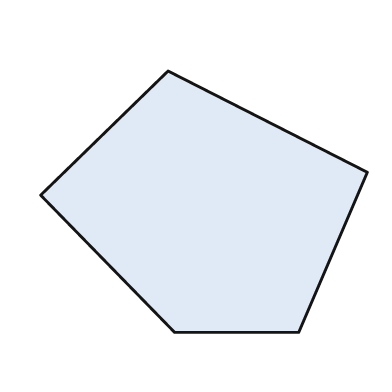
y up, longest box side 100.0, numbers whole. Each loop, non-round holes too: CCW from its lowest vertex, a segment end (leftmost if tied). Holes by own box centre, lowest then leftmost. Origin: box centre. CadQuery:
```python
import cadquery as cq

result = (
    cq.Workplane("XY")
    .moveTo(-9.0, -40.0)
    .lineTo(29.0, -40.0)
    .lineTo(50.0, 9.0)
    .lineTo(-11.0, 40.0)
    .lineTo(-50.0, 2.0)
    .close()
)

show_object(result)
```